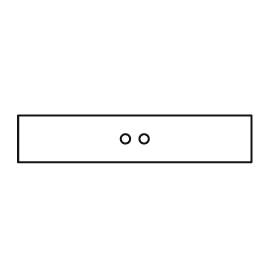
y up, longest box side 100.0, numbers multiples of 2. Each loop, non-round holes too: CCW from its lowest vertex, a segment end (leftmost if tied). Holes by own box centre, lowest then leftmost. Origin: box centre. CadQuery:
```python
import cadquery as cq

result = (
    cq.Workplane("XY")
    .moveTo(-50.0, -10.0)
    .lineTo(50.0, -10.0)
    .lineTo(50.0, 10.0)
    .lineTo(-50.0, 10.0)
    .close()
    .moveTo(-4.0, 0.0)
    .circle(2.0)
    .moveTo(4.0, 0.0)
    .circle(2.0)
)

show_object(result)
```